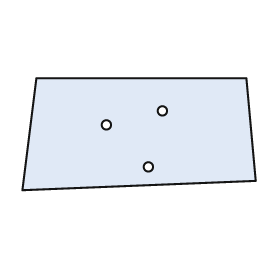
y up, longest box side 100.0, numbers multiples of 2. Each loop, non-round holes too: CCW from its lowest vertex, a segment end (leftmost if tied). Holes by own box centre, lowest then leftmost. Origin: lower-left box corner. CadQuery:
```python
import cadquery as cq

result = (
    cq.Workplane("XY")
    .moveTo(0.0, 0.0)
    .lineTo(100.0, 4.0)
    .lineTo(96.0, 48.0)
    .lineTo(6.0, 48.0)
    .close()
    .moveTo(54.0, 10.0)
    .circle(2.0)
    .moveTo(36.0, 28.0)
    .circle(2.0)
    .moveTo(60.0, 34.0)
    .circle(2.0)
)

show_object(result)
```